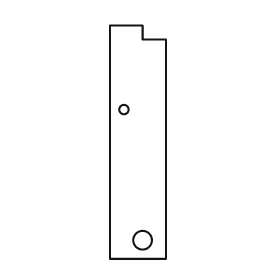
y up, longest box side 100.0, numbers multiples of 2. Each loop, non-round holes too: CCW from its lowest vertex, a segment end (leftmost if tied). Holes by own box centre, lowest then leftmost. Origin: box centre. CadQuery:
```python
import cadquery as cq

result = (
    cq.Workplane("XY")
    .moveTo(-12.0, -50.0)
    .lineTo(12.0, -50.0)
    .lineTo(12.0, 44.0)
    .lineTo(2.0, 44.0)
    .lineTo(2.0, 50.0)
    .lineTo(-12.0, 50.0)
    .close()
    .moveTo(2.0, -42.0)
    .circle(4.0)
    .moveTo(-6.0, 14.0)
    .circle(2.0)
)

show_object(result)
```